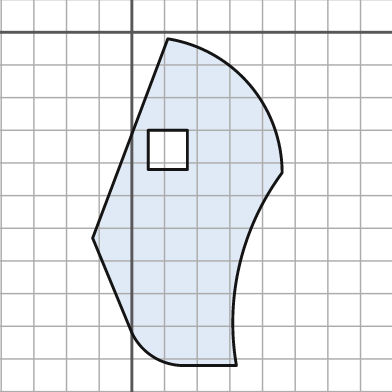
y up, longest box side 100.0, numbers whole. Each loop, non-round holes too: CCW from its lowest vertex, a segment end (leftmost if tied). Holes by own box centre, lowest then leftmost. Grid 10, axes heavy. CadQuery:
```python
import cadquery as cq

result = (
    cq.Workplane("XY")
    .moveTo(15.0, -102.0)
    .lineTo(32.0, -102.0)
    .threePointArc((33.0, -71.0), (46.0, -43.0))
    .threePointArc((36.0, -16.0), (11.0, -2.0))
    .lineTo(-12.0, -63.0)
    .lineTo(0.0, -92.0)
    .threePointArc((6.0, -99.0), (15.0, -102.0))
    .close()
    .moveTo(5.0, -42.0)
    .lineTo(17.0, -42.0)
    .lineTo(17.0, -30.0)
    .lineTo(5.0, -30.0)
    .close()
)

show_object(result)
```